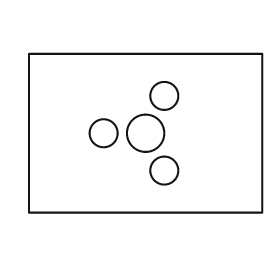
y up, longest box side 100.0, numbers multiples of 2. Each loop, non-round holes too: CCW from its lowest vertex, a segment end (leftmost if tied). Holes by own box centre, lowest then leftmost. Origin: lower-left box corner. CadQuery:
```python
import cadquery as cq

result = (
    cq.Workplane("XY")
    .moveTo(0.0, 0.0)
    .lineTo(100.0, 0.0)
    .lineTo(100.0, 68.0)
    .lineTo(0.0, 68.0)
    .close()
    .moveTo(58.0, 18.0)
    .circle(6.0)
    .moveTo(32.0, 34.0)
    .circle(6.0)
    .moveTo(50.0, 34.0)
    .circle(8.0)
    .moveTo(58.0, 50.0)
    .circle(6.0)
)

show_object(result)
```